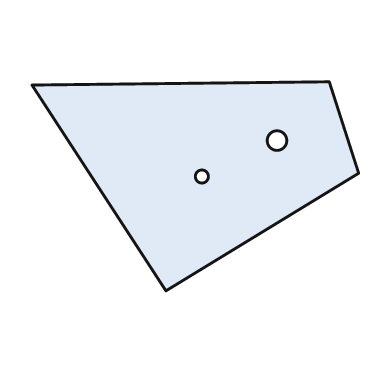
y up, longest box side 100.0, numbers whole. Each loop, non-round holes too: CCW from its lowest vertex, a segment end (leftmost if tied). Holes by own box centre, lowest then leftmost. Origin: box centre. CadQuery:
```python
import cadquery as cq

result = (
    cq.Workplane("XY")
    .moveTo(-9.0, -32.0)
    .lineTo(50.0, 4.0)
    .lineTo(41.0, 32.0)
    .lineTo(-50.0, 31.0)
    .close()
    .moveTo(2.0, 3.0)
    .circle(2.0)
    .moveTo(25.0, 14.0)
    .circle(3.0)
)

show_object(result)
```